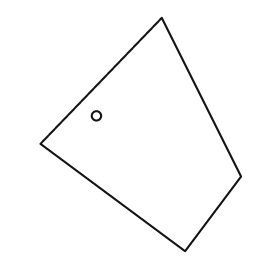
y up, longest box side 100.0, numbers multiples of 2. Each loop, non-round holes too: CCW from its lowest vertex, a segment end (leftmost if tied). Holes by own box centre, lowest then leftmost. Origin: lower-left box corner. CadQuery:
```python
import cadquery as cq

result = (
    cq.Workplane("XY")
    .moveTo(62.0, 0.0)
    .lineTo(86.0, 32.0)
    .lineTo(52.0, 100.0)
    .lineTo(0.0, 46.0)
    .close()
    .moveTo(24.0, 58.0)
    .circle(2.0)
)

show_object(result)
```